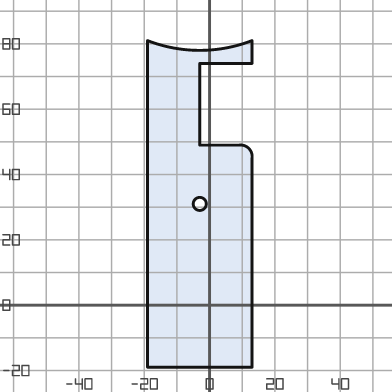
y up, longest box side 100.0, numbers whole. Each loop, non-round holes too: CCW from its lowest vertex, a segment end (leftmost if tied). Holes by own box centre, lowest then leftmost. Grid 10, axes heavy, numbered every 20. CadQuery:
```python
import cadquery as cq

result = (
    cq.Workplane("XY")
    .moveTo(-19.0, -19.0)
    .lineTo(13.0, -19.0)
    .lineTo(13.0, 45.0)
    .threePointArc((12.0, 48.0), (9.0, 49.0))
    .lineTo(-3.0, 49.0)
    .lineTo(-3.0, 74.0)
    .lineTo(13.0, 74.0)
    .lineTo(13.0, 81.0)
    .threePointArc((-3.0, 78.0), (-19.0, 81.0))
    .close()
    .moveTo(-3.0, 31.0)
    .circle(2.0)
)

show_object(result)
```